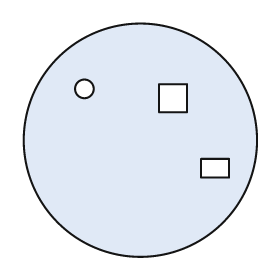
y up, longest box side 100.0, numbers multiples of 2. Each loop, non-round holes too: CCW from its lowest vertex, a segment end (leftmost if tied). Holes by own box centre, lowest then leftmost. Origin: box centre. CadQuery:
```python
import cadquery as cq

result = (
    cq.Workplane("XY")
    .moveTo(0.0, 0.0)
    .circle(50.0)
    .moveTo(26.0, -16.0)
    .lineTo(38.0, -16.0)
    .lineTo(38.0, -8.0)
    .lineTo(26.0, -8.0)
    .close()
    .moveTo(8.0, 12.0)
    .lineTo(20.0, 12.0)
    .lineTo(20.0, 24.0)
    .lineTo(8.0, 24.0)
    .close()
    .moveTo(-24.0, 22.0)
    .circle(4.0)
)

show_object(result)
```